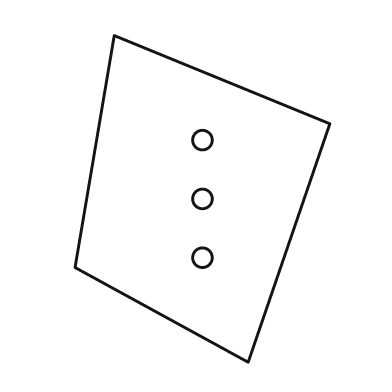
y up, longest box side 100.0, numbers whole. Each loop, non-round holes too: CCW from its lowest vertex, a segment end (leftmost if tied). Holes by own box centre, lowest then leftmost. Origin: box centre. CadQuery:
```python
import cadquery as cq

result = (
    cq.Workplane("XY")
    .moveTo(14.0, -50.0)
    .lineTo(39.0, 23.0)
    .lineTo(-27.0, 50.0)
    .lineTo(-39.0, -21.0)
    .close()
    .moveTo(0.0, -18.0)
    .circle(3.0)
    .moveTo(0.0, 0.0)
    .circle(3.0)
    .moveTo(0.0, 18.0)
    .circle(3.0)
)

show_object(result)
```